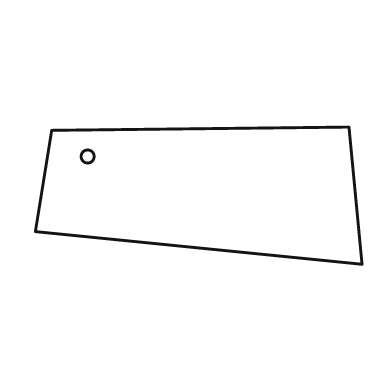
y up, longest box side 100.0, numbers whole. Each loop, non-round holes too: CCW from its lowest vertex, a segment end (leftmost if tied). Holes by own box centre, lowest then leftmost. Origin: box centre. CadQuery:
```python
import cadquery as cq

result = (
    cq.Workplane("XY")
    .moveTo(50.0, -21.0)
    .lineTo(46.0, 21.0)
    .lineTo(-45.0, 20.0)
    .lineTo(-50.0, -11.0)
    .close()
    .moveTo(-34.0, 12.0)
    .circle(2.0)
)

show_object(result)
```